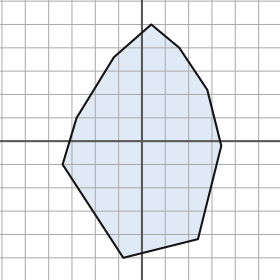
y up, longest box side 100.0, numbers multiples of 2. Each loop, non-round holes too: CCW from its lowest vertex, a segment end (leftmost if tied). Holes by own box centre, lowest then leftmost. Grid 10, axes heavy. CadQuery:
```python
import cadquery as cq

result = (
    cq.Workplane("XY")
    .moveTo(-8.0, -50.0)
    .lineTo(24.0, -42.0)
    .lineTo(34.0, -2.0)
    .lineTo(28.0, 22.0)
    .lineTo(16.0, 40.0)
    .lineTo(4.0, 50.0)
    .lineTo(-12.0, 36.0)
    .lineTo(-28.0, 10.0)
    .lineTo(-34.0, -10.0)
    .close()
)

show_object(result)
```